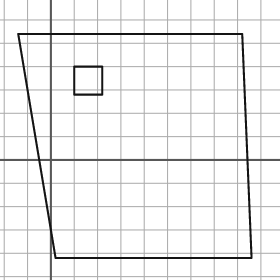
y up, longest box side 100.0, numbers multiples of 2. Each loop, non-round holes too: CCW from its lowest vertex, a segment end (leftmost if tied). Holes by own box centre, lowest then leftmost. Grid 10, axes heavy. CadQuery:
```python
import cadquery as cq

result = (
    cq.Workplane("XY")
    .moveTo(2.0, -42.0)
    .lineTo(86.0, -42.0)
    .lineTo(82.0, 54.0)
    .lineTo(-14.0, 54.0)
    .close()
    .moveTo(10.0, 28.0)
    .lineTo(22.0, 28.0)
    .lineTo(22.0, 40.0)
    .lineTo(10.0, 40.0)
    .close()
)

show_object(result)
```